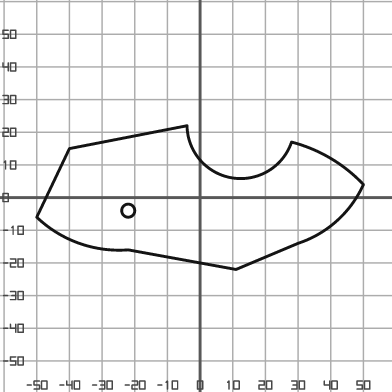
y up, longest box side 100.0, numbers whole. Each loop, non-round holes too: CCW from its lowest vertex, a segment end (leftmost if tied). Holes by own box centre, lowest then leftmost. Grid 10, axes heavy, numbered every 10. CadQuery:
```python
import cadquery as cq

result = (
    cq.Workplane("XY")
    .moveTo(11.0, -22.0)
    .lineTo(30.0, -14.0)
    .threePointArc((42.0, -7.0), (50.0, 4.0))
    .threePointArc((40.0, 12.0), (28.0, 17.0))
    .threePointArc((10.0, 6.0), (-4.0, 22.0))
    .lineTo(-40.0, 15.0)
    .lineTo(-50.0, -6.0)
    .threePointArc((-37.0, -14.0), (-22.0, -16.0))
    .close()
    .moveTo(-22.0, -4.0)
    .circle(2.0)
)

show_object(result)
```